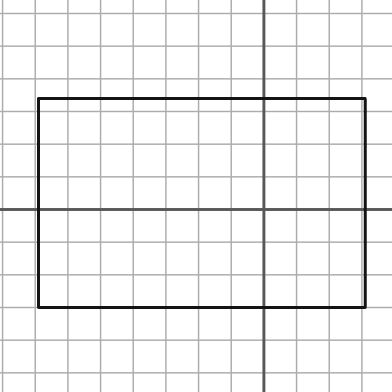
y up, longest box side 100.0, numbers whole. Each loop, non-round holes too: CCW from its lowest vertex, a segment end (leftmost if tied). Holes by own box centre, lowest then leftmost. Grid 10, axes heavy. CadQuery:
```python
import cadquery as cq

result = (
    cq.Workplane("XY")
    .moveTo(-69.0, -30.0)
    .lineTo(31.0, -30.0)
    .lineTo(31.0, 34.0)
    .lineTo(-69.0, 34.0)
    .close()
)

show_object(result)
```